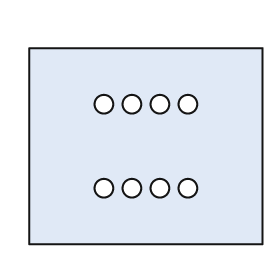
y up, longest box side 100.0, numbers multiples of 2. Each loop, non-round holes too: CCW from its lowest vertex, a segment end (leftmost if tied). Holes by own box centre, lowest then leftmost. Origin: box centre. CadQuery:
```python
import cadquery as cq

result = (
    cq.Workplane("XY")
    .moveTo(-50.0, -42.0)
    .lineTo(50.0, -42.0)
    .lineTo(50.0, 42.0)
    .lineTo(-50.0, 42.0)
    .close()
    .moveTo(-18.0, -18.0)
    .circle(4.0)
    .moveTo(-6.0, -18.0)
    .circle(4.0)
    .moveTo(6.0, -18.0)
    .circle(4.0)
    .moveTo(18.0, -18.0)
    .circle(4.0)
    .moveTo(-18.0, 18.0)
    .circle(4.0)
    .moveTo(-6.0, 18.0)
    .circle(4.0)
    .moveTo(6.0, 18.0)
    .circle(4.0)
    .moveTo(18.0, 18.0)
    .circle(4.0)
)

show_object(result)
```